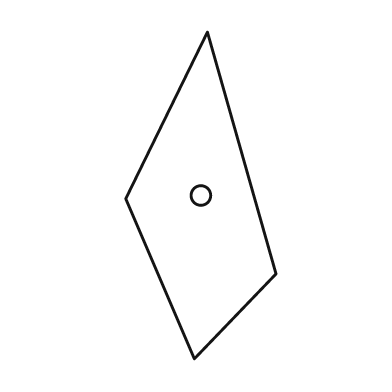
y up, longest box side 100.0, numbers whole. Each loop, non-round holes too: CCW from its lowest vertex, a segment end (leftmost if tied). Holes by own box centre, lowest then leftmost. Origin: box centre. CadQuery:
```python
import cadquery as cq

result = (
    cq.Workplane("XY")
    .moveTo(-2.0, -50.0)
    .lineTo(23.0, -24.0)
    .lineTo(2.0, 50.0)
    .lineTo(-23.0, -1.0)
    .close()
    .moveTo(0.0, 0.0)
    .circle(3.0)
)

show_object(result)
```